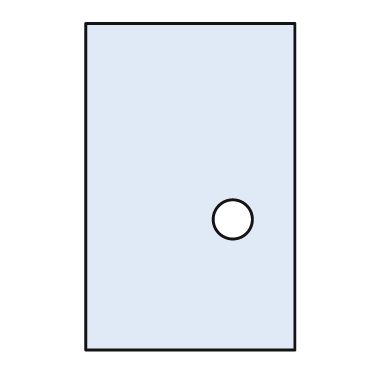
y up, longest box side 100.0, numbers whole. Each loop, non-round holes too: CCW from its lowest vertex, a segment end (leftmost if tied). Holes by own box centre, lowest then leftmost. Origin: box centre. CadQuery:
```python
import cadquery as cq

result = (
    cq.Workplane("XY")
    .moveTo(-32.0, -50.0)
    .lineTo(32.0, -50.0)
    .lineTo(32.0, 50.0)
    .lineTo(-32.0, 50.0)
    .close()
    .moveTo(13.0, -10.0)
    .circle(6.0)
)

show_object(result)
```